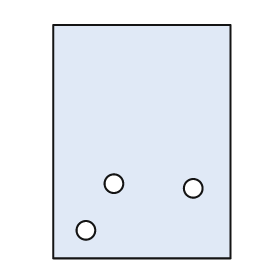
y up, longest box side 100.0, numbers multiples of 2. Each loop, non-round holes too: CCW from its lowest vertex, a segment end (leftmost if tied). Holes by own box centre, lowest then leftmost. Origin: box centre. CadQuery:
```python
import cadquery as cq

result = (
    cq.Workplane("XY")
    .moveTo(-38.0, -50.0)
    .lineTo(38.0, -50.0)
    .lineTo(38.0, 50.0)
    .lineTo(-38.0, 50.0)
    .close()
    .moveTo(-24.0, -38.0)
    .circle(4.0)
    .moveTo(22.0, -20.0)
    .circle(4.0)
    .moveTo(-12.0, -18.0)
    .circle(4.0)
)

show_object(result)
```